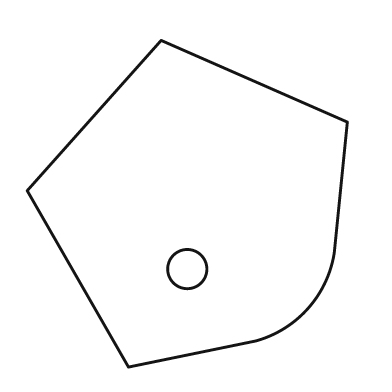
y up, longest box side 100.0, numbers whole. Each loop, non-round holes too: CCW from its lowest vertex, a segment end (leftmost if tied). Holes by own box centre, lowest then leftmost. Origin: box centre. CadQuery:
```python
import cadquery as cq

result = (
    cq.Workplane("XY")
    .moveTo(-18.0, -50.0)
    .lineTo(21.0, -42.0)
    .threePointArc((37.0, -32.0), (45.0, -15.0))
    .lineTo(49.0, 25.0)
    .lineTo(-8.0, 50.0)
    .lineTo(-49.0, 4.0)
    .close()
    .moveTo(0.0, -20.0)
    .circle(6.0)
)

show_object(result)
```